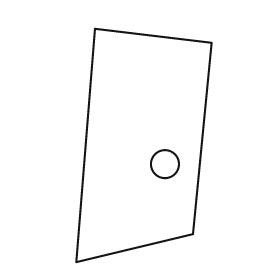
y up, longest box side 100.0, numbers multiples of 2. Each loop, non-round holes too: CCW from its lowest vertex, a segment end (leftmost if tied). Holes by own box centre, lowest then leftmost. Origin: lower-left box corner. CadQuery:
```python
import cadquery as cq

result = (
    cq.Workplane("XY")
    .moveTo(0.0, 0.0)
    .lineTo(50.0, 12.0)
    .lineTo(58.0, 94.0)
    .lineTo(8.0, 100.0)
    .close()
    .moveTo(38.0, 42.0)
    .circle(6.0)
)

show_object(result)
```